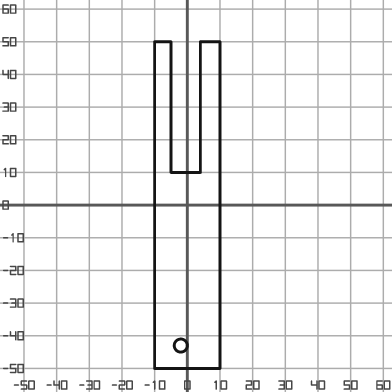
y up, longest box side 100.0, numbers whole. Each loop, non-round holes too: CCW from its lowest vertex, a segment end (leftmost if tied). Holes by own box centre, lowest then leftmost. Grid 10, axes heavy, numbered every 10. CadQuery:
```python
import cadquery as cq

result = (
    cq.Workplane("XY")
    .moveTo(-10.0, -50.0)
    .lineTo(10.0, -50.0)
    .lineTo(10.0, 50.0)
    .lineTo(4.0, 50.0)
    .lineTo(4.0, 10.0)
    .lineTo(-5.0, 10.0)
    .lineTo(-5.0, 50.0)
    .lineTo(-10.0, 50.0)
    .close()
    .moveTo(-2.0, -43.0)
    .circle(2.0)
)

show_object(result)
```